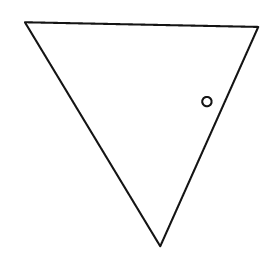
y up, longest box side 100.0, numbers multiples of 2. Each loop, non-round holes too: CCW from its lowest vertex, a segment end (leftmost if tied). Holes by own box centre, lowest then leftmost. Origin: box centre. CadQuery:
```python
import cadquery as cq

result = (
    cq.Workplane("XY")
    .moveTo(8.0, -48.0)
    .lineTo(50.0, 46.0)
    .lineTo(-50.0, 48.0)
    .close()
    .moveTo(28.0, 14.0)
    .circle(2.0)
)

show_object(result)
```